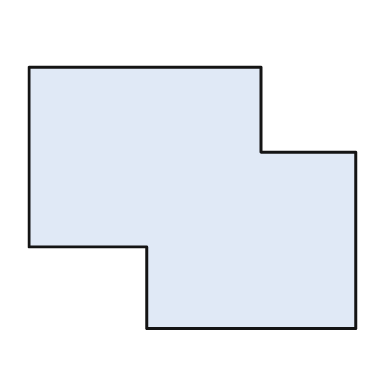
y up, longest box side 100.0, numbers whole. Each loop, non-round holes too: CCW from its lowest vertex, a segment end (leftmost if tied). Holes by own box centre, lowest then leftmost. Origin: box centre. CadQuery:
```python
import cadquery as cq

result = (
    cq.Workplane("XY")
    .moveTo(-14.0, -40.0)
    .lineTo(50.0, -40.0)
    .lineTo(50.0, 14.0)
    .lineTo(21.0, 14.0)
    .lineTo(21.0, 40.0)
    .lineTo(-50.0, 40.0)
    .lineTo(-50.0, -15.0)
    .lineTo(-14.0, -15.0)
    .close()
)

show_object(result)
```